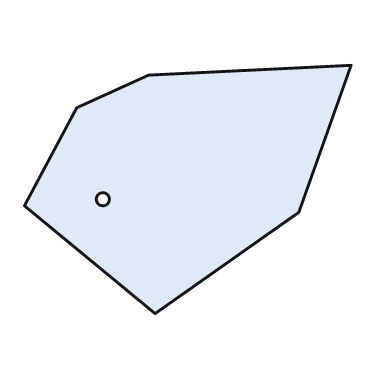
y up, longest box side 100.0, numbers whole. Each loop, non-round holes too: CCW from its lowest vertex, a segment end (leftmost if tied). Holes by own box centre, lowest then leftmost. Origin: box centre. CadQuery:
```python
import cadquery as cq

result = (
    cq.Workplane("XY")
    .moveTo(-10.0, -38.0)
    .lineTo(34.0, -7.0)
    .lineTo(50.0, 38.0)
    .lineTo(-12.0, 35.0)
    .lineTo(-34.0, 25.0)
    .lineTo(-50.0, -5.0)
    .close()
    .moveTo(-26.0, -3.0)
    .circle(2.0)
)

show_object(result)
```